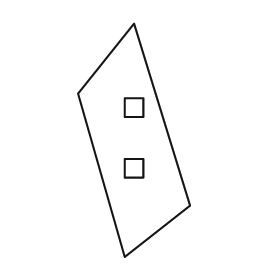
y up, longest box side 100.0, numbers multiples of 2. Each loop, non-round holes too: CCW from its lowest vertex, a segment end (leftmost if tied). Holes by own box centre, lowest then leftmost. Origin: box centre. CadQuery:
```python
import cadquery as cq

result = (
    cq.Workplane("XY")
    .moveTo(-4.0, -50.0)
    .lineTo(24.0, -28.0)
    .lineTo(0.0, 50.0)
    .lineTo(-24.0, 20.0)
    .close()
    .moveTo(-4.0, -16.0)
    .lineTo(4.0, -16.0)
    .lineTo(4.0, -8.0)
    .lineTo(-4.0, -8.0)
    .close()
    .moveTo(-4.0, 10.0)
    .lineTo(4.0, 10.0)
    .lineTo(4.0, 18.0)
    .lineTo(-4.0, 18.0)
    .close()
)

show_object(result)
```